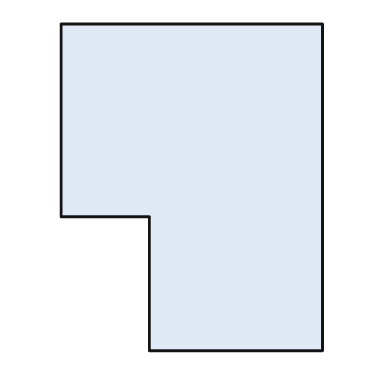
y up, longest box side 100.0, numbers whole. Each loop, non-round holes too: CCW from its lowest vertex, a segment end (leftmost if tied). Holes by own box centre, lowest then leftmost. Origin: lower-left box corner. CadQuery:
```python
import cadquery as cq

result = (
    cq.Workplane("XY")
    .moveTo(27.0, 0.0)
    .lineTo(80.0, 0.0)
    .lineTo(80.0, 100.0)
    .lineTo(0.0, 100.0)
    .lineTo(0.0, 41.0)
    .lineTo(27.0, 41.0)
    .close()
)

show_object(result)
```